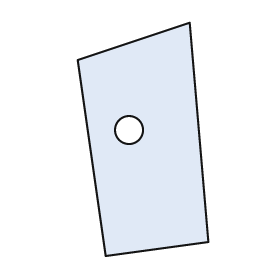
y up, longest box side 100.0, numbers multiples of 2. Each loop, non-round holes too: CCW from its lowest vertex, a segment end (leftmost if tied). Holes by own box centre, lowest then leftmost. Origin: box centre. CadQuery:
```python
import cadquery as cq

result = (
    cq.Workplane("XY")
    .moveTo(-16.0, -50.0)
    .lineTo(28.0, -44.0)
    .lineTo(20.0, 50.0)
    .lineTo(-28.0, 34.0)
    .close()
    .moveTo(-6.0, 4.0)
    .circle(6.0)
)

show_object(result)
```